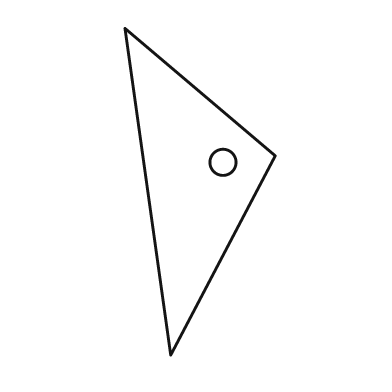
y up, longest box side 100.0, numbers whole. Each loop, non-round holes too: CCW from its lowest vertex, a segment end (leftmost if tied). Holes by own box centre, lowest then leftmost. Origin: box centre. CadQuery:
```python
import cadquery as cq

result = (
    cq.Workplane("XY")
    .moveTo(-9.0, -50.0)
    .lineTo(23.0, 11.0)
    .lineTo(-23.0, 50.0)
    .close()
    .moveTo(7.0, 9.0)
    .circle(4.0)
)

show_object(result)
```